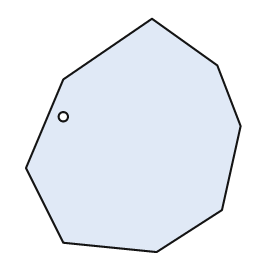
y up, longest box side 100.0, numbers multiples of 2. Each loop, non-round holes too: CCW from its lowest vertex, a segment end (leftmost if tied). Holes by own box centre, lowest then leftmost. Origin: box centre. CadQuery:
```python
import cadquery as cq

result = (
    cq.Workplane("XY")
    .moveTo(10.0, -50.0)
    .lineTo(38.0, -32.0)
    .lineTo(46.0, 4.0)
    .lineTo(36.0, 30.0)
    .lineTo(8.0, 50.0)
    .lineTo(-30.0, 24.0)
    .lineTo(-46.0, -14.0)
    .lineTo(-30.0, -46.0)
    .close()
    .moveTo(-30.0, 8.0)
    .circle(2.0)
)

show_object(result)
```